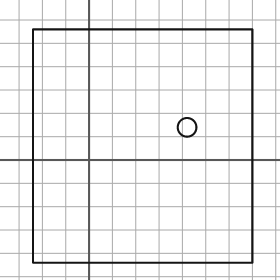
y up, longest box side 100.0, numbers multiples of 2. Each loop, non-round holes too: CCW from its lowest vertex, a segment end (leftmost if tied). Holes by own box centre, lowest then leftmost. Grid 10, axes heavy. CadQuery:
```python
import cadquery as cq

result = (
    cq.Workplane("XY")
    .moveTo(-24.0, -44.0)
    .lineTo(70.0, -44.0)
    .lineTo(70.0, 56.0)
    .lineTo(-24.0, 56.0)
    .close()
    .moveTo(42.0, 14.0)
    .circle(4.0)
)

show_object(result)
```